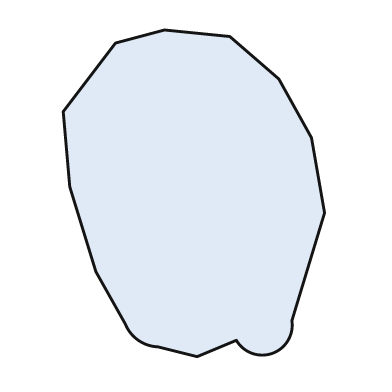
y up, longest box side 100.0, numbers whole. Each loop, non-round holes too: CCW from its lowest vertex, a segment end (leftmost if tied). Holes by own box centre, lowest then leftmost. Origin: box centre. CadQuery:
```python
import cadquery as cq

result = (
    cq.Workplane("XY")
    .moveTo(1.0, -50.0)
    .lineTo(13.0, -45.0)
    .threePointArc((24.0, -49.0), (30.0, -39.0))
    .lineTo(40.0, -6.0)
    .lineTo(36.0, 17.0)
    .lineTo(26.0, 35.0)
    .lineTo(11.0, 48.0)
    .lineTo(-9.0, 50.0)
    .lineTo(-24.0, 46.0)
    .lineTo(-40.0, 25.0)
    .lineTo(-38.0, 2.0)
    .lineTo(-30.0, -24.0)
    .lineTo(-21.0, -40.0)
    .threePointArc((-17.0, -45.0), (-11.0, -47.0))
    .close()
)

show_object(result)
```